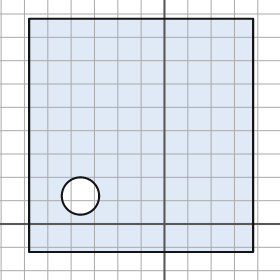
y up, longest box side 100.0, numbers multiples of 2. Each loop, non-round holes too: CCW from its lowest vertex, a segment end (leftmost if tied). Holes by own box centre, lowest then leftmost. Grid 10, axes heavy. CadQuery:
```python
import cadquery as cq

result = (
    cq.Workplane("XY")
    .moveTo(-58.0, -12.0)
    .lineTo(38.0, -12.0)
    .lineTo(38.0, 88.0)
    .lineTo(-58.0, 88.0)
    .close()
    .moveTo(-36.0, 12.0)
    .circle(8.0)
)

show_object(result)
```